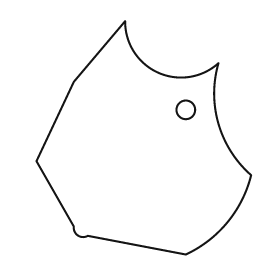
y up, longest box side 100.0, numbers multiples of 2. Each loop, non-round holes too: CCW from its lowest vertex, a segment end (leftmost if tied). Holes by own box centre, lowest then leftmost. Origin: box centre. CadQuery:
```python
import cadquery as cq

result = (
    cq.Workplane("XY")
    .moveTo(18.0, -50.0)
    .threePointArc((36.0, -36.0), (46.0, -16.0))
    .threePointArc((32.0, 6.0), (32.0, 32.0))
    .threePointArc((6.0, 28.0), (-8.0, 50.0))
    .lineTo(-30.0, 24.0)
    .lineTo(-46.0, -10.0)
    .lineTo(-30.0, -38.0)
    .threePointArc((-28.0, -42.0), (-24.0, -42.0))
    .close()
    .moveTo(18.0, 12.0)
    .circle(4.0)
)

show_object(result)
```